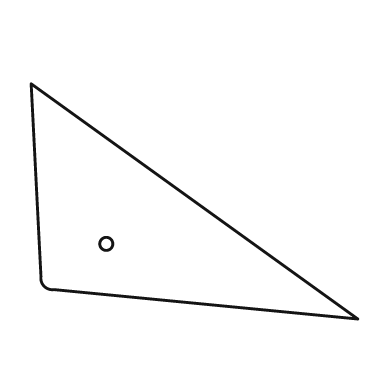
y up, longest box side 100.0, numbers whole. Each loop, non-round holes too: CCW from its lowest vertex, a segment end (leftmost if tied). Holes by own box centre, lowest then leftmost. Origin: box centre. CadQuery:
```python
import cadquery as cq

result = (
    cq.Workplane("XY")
    .moveTo(50.0, -36.0)
    .lineTo(-50.0, 36.0)
    .lineTo(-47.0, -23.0)
    .threePointArc((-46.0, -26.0), (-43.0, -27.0))
    .close()
    .moveTo(-27.0, -13.0)
    .circle(2.0)
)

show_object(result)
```